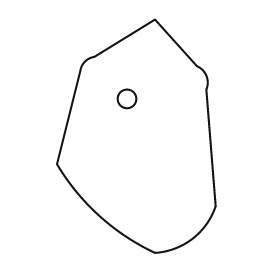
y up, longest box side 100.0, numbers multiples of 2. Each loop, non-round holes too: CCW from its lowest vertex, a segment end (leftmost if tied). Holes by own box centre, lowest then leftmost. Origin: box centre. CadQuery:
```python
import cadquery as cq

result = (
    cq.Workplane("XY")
    .moveTo(8.0, -50.0)
    .threePointArc((24.0, -44.0), (34.0, -30.0))
    .lineTo(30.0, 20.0)
    .threePointArc((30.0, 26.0), (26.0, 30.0))
    .lineTo(8.0, 50.0)
    .lineTo(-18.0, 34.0)
    .threePointArc((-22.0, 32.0), (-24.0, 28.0))
    .lineTo(-34.0, -12.0)
    .threePointArc((-16.0, -34.0), (8.0, -50.0))
    .close()
    .moveTo(-4.0, 16.0)
    .circle(4.0)
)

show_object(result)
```